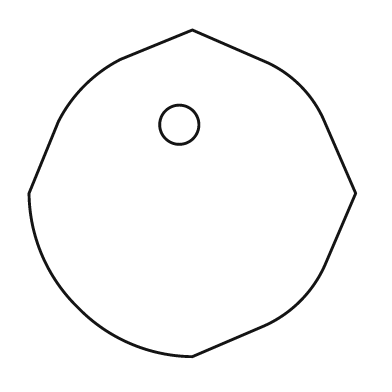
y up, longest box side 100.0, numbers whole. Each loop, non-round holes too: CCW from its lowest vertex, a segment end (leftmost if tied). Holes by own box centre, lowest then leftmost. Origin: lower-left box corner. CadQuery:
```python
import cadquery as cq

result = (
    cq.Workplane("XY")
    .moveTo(50.0, 0.0)
    .lineTo(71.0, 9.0)
    .threePointArc((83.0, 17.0), (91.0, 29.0))
    .lineTo(100.0, 50.0)
    .lineTo(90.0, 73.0)
    .threePointArc((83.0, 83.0), (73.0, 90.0))
    .lineTo(50.0, 100.0)
    .lineTo(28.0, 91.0)
    .threePointArc((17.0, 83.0), (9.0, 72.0))
    .lineTo(0.0, 50.0)
    .threePointArc((4.0, 31.0), (15.0, 15.0))
    .threePointArc((31.0, 4.0), (50.0, 0.0))
    .close()
    .moveTo(46.0, 71.0)
    .circle(6.0)
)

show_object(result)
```